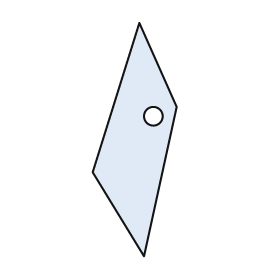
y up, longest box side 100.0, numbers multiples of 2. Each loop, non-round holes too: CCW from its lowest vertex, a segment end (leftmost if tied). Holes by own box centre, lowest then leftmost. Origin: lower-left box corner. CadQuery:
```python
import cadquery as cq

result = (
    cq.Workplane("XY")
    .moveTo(22.0, 0.0)
    .lineTo(36.0, 64.0)
    .lineTo(20.0, 100.0)
    .lineTo(0.0, 36.0)
    .close()
    .moveTo(26.0, 60.0)
    .circle(4.0)
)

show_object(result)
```